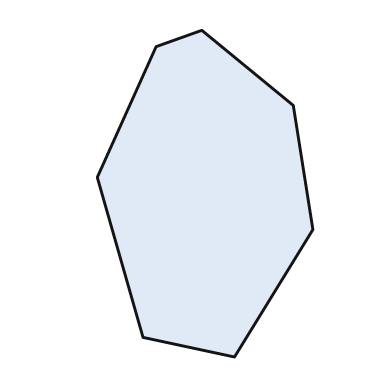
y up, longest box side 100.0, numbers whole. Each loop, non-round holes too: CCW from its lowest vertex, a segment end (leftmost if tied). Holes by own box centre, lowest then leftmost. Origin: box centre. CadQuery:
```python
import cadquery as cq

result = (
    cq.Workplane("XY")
    .moveTo(9.0, -50.0)
    .lineTo(33.0, -11.0)
    .lineTo(27.0, 27.0)
    .lineTo(-1.0, 50.0)
    .lineTo(-15.0, 45.0)
    .lineTo(-33.0, 5.0)
    .lineTo(-19.0, -44.0)
    .close()
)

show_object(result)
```